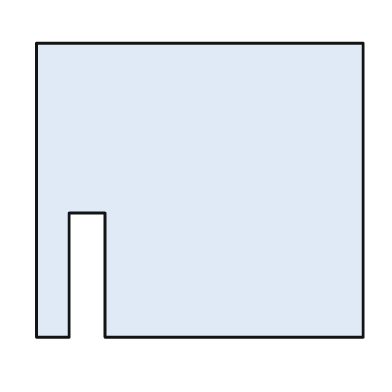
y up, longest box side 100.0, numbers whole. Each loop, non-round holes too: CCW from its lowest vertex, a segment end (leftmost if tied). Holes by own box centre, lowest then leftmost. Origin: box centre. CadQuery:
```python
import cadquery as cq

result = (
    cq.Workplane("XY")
    .moveTo(-50.0, -45.0)
    .lineTo(-40.0, -45.0)
    .lineTo(-40.0, -7.0)
    .lineTo(-29.0, -7.0)
    .lineTo(-29.0, -45.0)
    .lineTo(50.0, -45.0)
    .lineTo(50.0, 45.0)
    .lineTo(-50.0, 45.0)
    .close()
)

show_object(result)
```